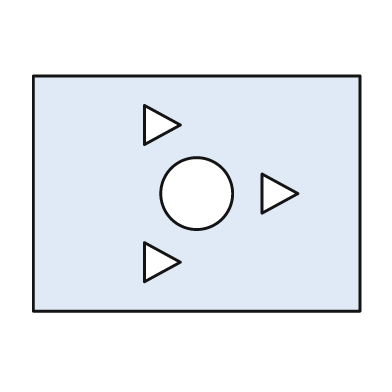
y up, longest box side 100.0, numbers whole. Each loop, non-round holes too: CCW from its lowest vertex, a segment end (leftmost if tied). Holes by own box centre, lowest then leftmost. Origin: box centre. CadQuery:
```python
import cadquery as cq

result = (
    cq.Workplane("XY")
    .moveTo(-50.0, -36.0)
    .lineTo(50.0, -36.0)
    .lineTo(50.0, 36.0)
    .lineTo(-50.0, 36.0)
    .close()
    .moveTo(-16.0, -27.0)
    .lineTo(-5.0, -21.0)
    .lineTo(-16.0, -15.0)
    .close()
    .moveTo(0.0, 0.0)
    .circle(11.0)
    .moveTo(20.0, -6.0)
    .lineTo(31.0, 0.0)
    .lineTo(20.0, 6.0)
    .close()
    .moveTo(-16.0, 15.0)
    .lineTo(-5.0, 21.0)
    .lineTo(-16.0, 27.0)
    .close()
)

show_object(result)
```